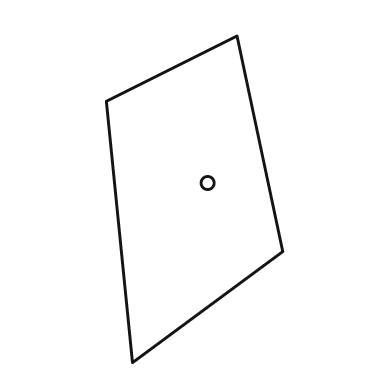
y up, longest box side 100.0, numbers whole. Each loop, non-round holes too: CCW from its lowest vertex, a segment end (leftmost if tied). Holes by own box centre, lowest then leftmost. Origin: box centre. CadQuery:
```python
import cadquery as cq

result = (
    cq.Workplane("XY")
    .moveTo(-19.0, -50.0)
    .lineTo(27.0, -16.0)
    .lineTo(13.0, 50.0)
    .lineTo(-27.0, 30.0)
    .close()
    .moveTo(4.0, 5.0)
    .circle(2.0)
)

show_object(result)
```